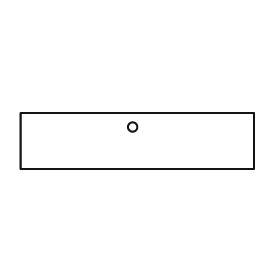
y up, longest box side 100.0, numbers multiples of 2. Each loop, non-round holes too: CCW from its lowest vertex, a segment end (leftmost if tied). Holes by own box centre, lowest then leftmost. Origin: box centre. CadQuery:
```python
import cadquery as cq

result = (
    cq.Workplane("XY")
    .moveTo(-50.0, -12.0)
    .lineTo(50.0, -12.0)
    .lineTo(50.0, 12.0)
    .lineTo(-50.0, 12.0)
    .close()
    .moveTo(-2.0, 6.0)
    .circle(2.0)
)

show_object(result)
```